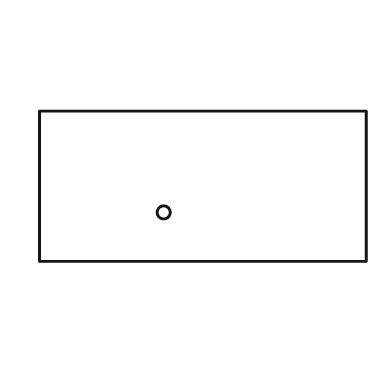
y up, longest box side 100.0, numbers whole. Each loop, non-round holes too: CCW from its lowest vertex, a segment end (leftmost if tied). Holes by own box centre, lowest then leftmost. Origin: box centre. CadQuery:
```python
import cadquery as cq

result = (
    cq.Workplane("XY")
    .moveTo(-50.0, -23.0)
    .lineTo(50.0, -23.0)
    .lineTo(50.0, 23.0)
    .lineTo(-50.0, 23.0)
    .close()
    .moveTo(-12.0, -8.0)
    .circle(2.0)
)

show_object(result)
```